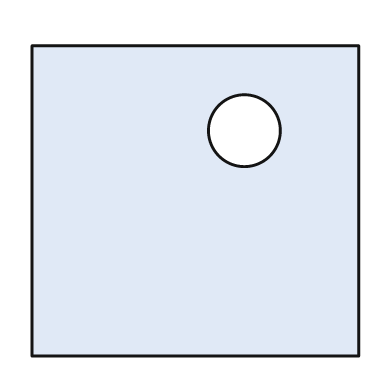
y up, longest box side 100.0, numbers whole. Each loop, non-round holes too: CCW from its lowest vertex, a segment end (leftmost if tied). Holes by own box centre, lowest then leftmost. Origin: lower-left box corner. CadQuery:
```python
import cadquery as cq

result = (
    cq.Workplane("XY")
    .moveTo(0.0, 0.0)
    .lineTo(100.0, 0.0)
    .lineTo(100.0, 95.0)
    .lineTo(0.0, 95.0)
    .close()
    .moveTo(65.0, 69.0)
    .circle(11.0)
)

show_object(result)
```